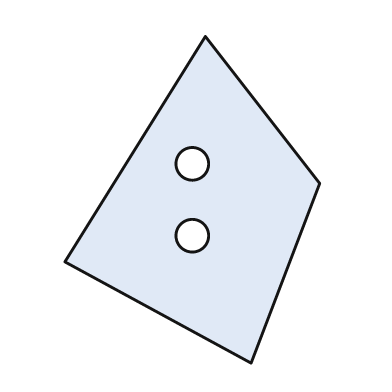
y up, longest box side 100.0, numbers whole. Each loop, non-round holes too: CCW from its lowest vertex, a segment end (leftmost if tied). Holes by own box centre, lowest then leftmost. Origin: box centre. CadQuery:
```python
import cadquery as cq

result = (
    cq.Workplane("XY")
    .moveTo(18.0, -50.0)
    .lineTo(39.0, 5.0)
    .lineTo(4.0, 50.0)
    .lineTo(-39.0, -19.0)
    .close()
    .moveTo(0.0, -11.0)
    .circle(5.0)
    .moveTo(0.0, 11.0)
    .circle(5.0)
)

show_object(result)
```